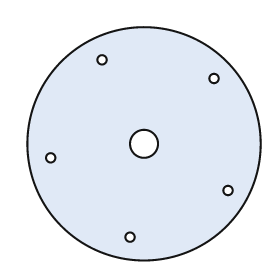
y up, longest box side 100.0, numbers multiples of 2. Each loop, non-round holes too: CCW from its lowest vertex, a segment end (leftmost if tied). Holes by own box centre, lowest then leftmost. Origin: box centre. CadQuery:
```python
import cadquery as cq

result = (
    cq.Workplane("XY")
    .moveTo(0.0, 0.0)
    .circle(50.0)
    .moveTo(-6.0, -40.0)
    .circle(2.0)
    .moveTo(36.0, -20.0)
    .circle(2.0)
    .moveTo(-40.0, -6.0)
    .circle(2.0)
    .moveTo(0.0, 0.0)
    .circle(6.0)
    .moveTo(30.0, 28.0)
    .circle(2.0)
    .moveTo(-18.0, 36.0)
    .circle(2.0)
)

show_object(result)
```